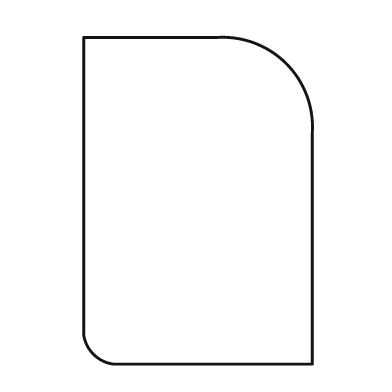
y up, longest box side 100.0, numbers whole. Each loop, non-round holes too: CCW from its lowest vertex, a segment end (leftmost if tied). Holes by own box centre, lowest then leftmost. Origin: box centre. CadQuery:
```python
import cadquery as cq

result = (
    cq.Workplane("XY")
    .moveTo(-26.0, -50.0)
    .lineTo(35.0, -50.0)
    .lineTo(35.0, 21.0)
    .threePointArc((27.0, 42.0), (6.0, 50.0))
    .lineTo(-35.0, 50.0)
    .lineTo(-35.0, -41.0)
    .threePointArc((-32.0, -47.0), (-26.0, -50.0))
    .close()
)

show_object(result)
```